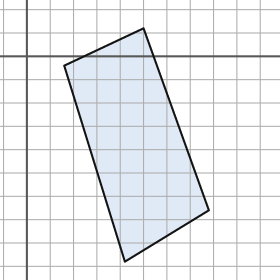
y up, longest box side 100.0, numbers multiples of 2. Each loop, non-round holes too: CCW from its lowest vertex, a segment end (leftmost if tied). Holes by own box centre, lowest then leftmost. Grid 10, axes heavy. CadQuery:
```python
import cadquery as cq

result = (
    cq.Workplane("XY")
    .moveTo(42.0, -88.0)
    .lineTo(78.0, -66.0)
    .lineTo(50.0, 12.0)
    .lineTo(16.0, -4.0)
    .close()
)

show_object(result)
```